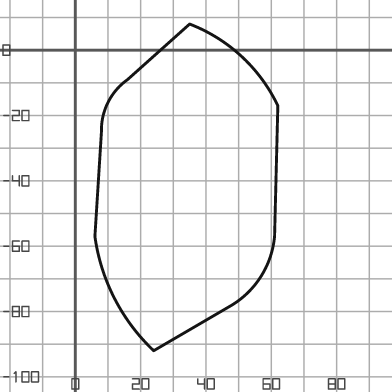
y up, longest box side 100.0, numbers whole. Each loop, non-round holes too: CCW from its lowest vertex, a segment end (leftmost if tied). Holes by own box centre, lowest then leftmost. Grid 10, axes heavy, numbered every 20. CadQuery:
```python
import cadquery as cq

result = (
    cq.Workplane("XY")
    .moveTo(24.0, -92.0)
    .lineTo(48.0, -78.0)
    .threePointArc((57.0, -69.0), (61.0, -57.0))
    .lineTo(62.0, -17.0)
    .threePointArc((51.0, -2.0), (35.0, 8.0))
    .lineTo(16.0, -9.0)
    .threePointArc((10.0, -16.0), (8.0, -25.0))
    .lineTo(6.0, -57.0)
    .threePointArc((12.0, -76.0), (24.0, -92.0))
    .close()
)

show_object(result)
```